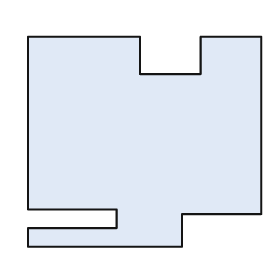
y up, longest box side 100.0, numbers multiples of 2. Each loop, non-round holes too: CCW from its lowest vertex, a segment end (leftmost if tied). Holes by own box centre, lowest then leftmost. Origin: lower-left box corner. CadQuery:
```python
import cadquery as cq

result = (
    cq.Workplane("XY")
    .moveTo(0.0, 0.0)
    .lineTo(66.0, 0.0)
    .lineTo(66.0, 14.0)
    .lineTo(100.0, 14.0)
    .lineTo(100.0, 90.0)
    .lineTo(74.0, 90.0)
    .lineTo(74.0, 74.0)
    .lineTo(48.0, 74.0)
    .lineTo(48.0, 90.0)
    .lineTo(0.0, 90.0)
    .lineTo(0.0, 16.0)
    .lineTo(38.0, 16.0)
    .lineTo(38.0, 8.0)
    .lineTo(0.0, 8.0)
    .close()
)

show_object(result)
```